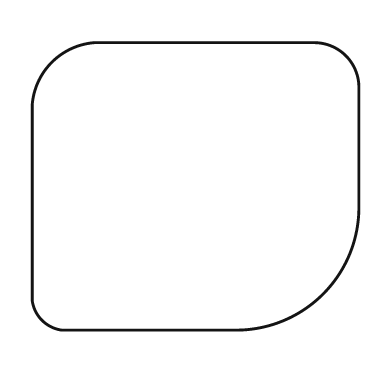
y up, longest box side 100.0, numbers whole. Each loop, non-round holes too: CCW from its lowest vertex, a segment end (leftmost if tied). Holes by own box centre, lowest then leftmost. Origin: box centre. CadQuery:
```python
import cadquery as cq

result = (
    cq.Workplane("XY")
    .moveTo(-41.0, -44.0)
    .lineTo(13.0, -44.0)
    .threePointArc((39.0, -33.0), (50.0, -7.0))
    .lineTo(50.0, 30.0)
    .threePointArc((46.0, 40.0), (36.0, 44.0))
    .lineTo(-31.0, 44.0)
    .threePointArc((-44.0, 38.0), (-50.0, 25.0))
    .lineTo(-50.0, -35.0)
    .threePointArc((-47.0, -41.0), (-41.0, -44.0))
    .close()
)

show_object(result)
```